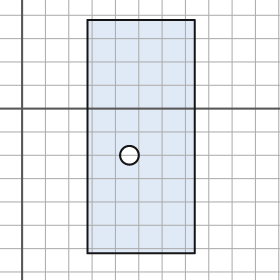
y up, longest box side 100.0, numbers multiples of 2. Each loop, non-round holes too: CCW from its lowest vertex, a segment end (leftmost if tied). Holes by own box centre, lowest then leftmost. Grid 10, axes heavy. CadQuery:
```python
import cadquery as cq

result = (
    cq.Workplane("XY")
    .moveTo(28.0, -62.0)
    .lineTo(74.0, -62.0)
    .lineTo(74.0, 38.0)
    .lineTo(28.0, 38.0)
    .close()
    .moveTo(46.0, -20.0)
    .circle(4.0)
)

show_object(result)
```